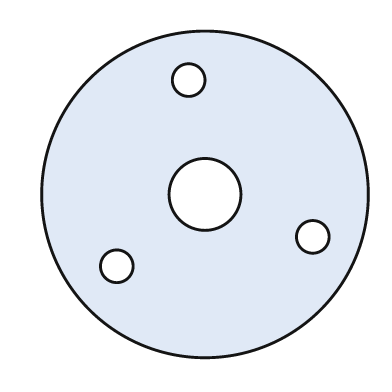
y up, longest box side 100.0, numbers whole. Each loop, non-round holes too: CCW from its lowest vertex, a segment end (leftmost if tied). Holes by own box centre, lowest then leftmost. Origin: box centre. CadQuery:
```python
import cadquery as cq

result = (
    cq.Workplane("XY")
    .moveTo(0.0, 0.0)
    .circle(50.0)
    .moveTo(-27.0, -22.0)
    .circle(5.0)
    .moveTo(33.0, -13.0)
    .circle(5.0)
    .moveTo(0.0, 0.0)
    .circle(11.0)
    .moveTo(-5.0, 35.0)
    .circle(5.0)
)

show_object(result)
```